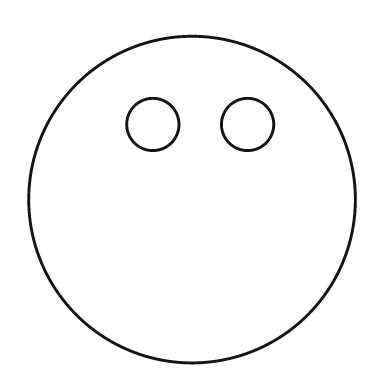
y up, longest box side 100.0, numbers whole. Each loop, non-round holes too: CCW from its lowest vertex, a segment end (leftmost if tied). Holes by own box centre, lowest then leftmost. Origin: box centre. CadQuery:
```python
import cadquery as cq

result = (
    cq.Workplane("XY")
    .moveTo(0.0, 0.0)
    .circle(50.0)
    .moveTo(-12.0, 23.0)
    .circle(8.0)
    .moveTo(17.0, 23.0)
    .circle(8.0)
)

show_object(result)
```